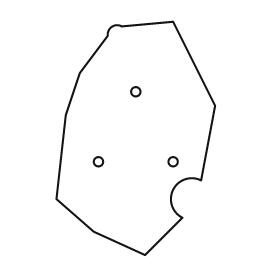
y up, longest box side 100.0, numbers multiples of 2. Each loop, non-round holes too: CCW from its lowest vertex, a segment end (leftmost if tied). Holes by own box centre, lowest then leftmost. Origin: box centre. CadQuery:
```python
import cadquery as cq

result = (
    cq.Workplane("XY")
    .moveTo(4.0, -50.0)
    .lineTo(20.0, -34.0)
    .threePointArc((16.0, -22.0), (28.0, -18.0))
    .lineTo(34.0, 14.0)
    .lineTo(16.0, 50.0)
    .lineTo(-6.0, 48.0)
    .threePointArc((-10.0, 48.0), (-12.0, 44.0))
    .lineTo(-24.0, 28.0)
    .lineTo(-30.0, 10.0)
    .lineTo(-34.0, -26.0)
    .lineTo(-18.0, -40.0)
    .close()
    .moveTo(-16.0, -10.0)
    .circle(2.0)
    .moveTo(16.0, -10.0)
    .circle(2.0)
    .moveTo(0.0, 20.0)
    .circle(2.0)
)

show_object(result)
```